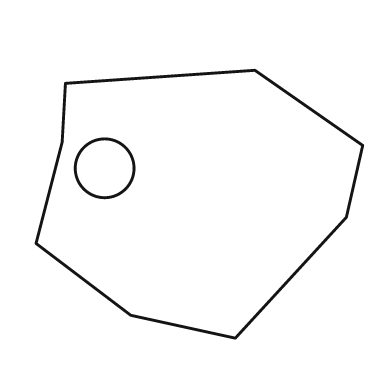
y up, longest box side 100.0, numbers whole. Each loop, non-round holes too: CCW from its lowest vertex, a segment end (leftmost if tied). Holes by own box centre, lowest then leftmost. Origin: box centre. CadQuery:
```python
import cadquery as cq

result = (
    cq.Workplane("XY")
    .moveTo(11.0, -41.0)
    .lineTo(45.0, -4.0)
    .lineTo(50.0, 18.0)
    .lineTo(17.0, 41.0)
    .lineTo(-41.0, 37.0)
    .lineTo(-42.0, 19.0)
    .lineTo(-50.0, -12.0)
    .lineTo(-21.0, -34.0)
    .close()
    .moveTo(-29.0, 11.0)
    .circle(9.0)
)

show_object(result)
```